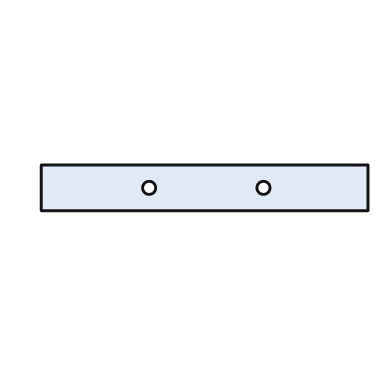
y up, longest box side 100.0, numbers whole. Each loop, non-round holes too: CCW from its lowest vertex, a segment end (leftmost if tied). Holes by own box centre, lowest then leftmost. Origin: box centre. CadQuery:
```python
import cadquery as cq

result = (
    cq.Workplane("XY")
    .moveTo(-50.0, -7.0)
    .lineTo(50.0, -7.0)
    .lineTo(50.0, 7.0)
    .lineTo(-50.0, 7.0)
    .close()
    .moveTo(-17.0, 0.0)
    .circle(2.0)
    .moveTo(18.0, 0.0)
    .circle(2.0)
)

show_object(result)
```